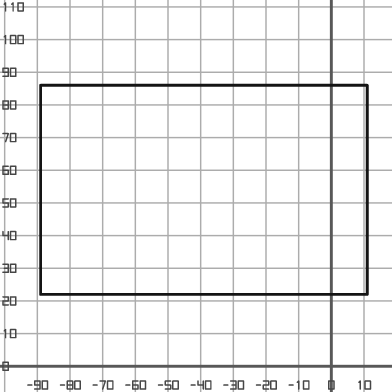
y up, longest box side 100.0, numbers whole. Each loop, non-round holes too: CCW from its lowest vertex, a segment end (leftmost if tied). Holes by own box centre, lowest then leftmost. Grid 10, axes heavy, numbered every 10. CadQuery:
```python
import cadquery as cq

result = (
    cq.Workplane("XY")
    .moveTo(-89.0, 22.0)
    .lineTo(11.0, 22.0)
    .lineTo(11.0, 86.0)
    .lineTo(-89.0, 86.0)
    .close()
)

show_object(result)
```